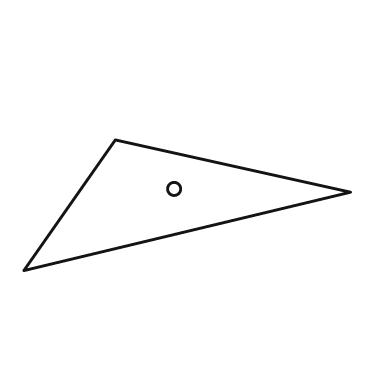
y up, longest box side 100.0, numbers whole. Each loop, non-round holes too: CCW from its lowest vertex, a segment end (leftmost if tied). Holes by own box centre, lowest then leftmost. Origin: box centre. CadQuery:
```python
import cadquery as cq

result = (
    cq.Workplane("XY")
    .moveTo(-50.0, -20.0)
    .lineTo(50.0, 4.0)
    .lineTo(-22.0, 20.0)
    .close()
    .moveTo(-4.0, 5.0)
    .circle(2.0)
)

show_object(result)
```